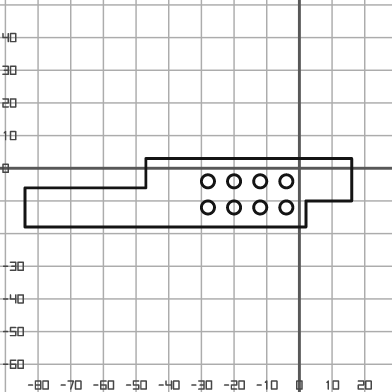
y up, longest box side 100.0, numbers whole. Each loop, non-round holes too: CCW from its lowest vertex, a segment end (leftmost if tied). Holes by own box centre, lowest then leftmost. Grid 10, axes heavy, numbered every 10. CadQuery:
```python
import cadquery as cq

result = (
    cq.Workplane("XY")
    .moveTo(-84.0, -18.0)
    .lineTo(2.0, -18.0)
    .lineTo(2.0, -10.0)
    .lineTo(16.0, -10.0)
    .lineTo(16.0, 3.0)
    .lineTo(-47.0, 3.0)
    .lineTo(-47.0, -6.0)
    .lineTo(-84.0, -6.0)
    .close()
    .moveTo(-28.0, -12.0)
    .circle(2.0)
    .moveTo(-20.0, -12.0)
    .circle(2.0)
    .moveTo(-12.0, -12.0)
    .circle(2.0)
    .moveTo(-4.0, -12.0)
    .circle(2.0)
    .moveTo(-28.0, -4.0)
    .circle(2.0)
    .moveTo(-20.0, -4.0)
    .circle(2.0)
    .moveTo(-12.0, -4.0)
    .circle(2.0)
    .moveTo(-4.0, -4.0)
    .circle(2.0)
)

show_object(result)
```